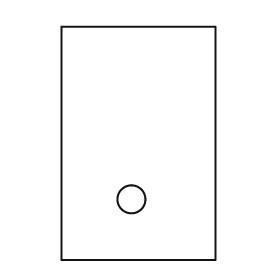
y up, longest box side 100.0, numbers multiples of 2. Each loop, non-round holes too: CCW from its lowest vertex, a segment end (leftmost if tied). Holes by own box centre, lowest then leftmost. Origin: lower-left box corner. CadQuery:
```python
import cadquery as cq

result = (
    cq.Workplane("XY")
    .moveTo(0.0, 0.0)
    .lineTo(66.0, 0.0)
    .lineTo(66.0, 100.0)
    .lineTo(0.0, 100.0)
    .close()
    .moveTo(30.0, 26.0)
    .circle(6.0)
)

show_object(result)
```